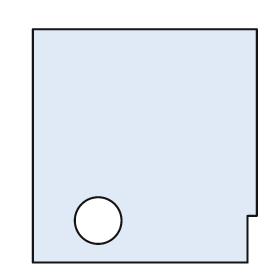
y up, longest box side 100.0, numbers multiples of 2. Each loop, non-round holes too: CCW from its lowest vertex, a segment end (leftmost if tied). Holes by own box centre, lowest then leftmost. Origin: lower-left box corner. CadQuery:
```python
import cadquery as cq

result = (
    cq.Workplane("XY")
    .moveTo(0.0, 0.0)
    .lineTo(92.0, 0.0)
    .lineTo(92.0, 20.0)
    .lineTo(96.0, 20.0)
    .lineTo(96.0, 100.0)
    .lineTo(0.0, 100.0)
    .close()
    .moveTo(28.0, 18.0)
    .circle(10.0)
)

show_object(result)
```